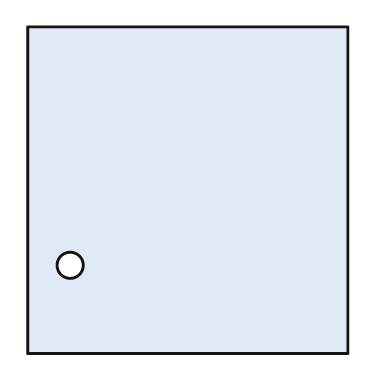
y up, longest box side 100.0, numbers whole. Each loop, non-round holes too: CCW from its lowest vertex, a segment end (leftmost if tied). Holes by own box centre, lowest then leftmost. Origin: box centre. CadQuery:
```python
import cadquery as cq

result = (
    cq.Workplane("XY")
    .moveTo(-49.0, -50.0)
    .lineTo(49.0, -50.0)
    .lineTo(49.0, 50.0)
    .lineTo(-49.0, 50.0)
    .close()
    .moveTo(-36.0, -23.0)
    .circle(4.0)
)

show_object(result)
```